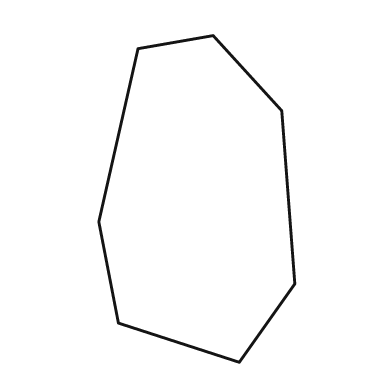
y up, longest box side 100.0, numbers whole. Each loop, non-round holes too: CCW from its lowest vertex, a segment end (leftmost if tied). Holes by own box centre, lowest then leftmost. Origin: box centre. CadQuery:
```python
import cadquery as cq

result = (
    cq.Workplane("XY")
    .moveTo(13.0, -50.0)
    .lineTo(30.0, -26.0)
    .lineTo(26.0, 27.0)
    .lineTo(5.0, 50.0)
    .lineTo(-18.0, 46.0)
    .lineTo(-30.0, -7.0)
    .lineTo(-24.0, -38.0)
    .close()
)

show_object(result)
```